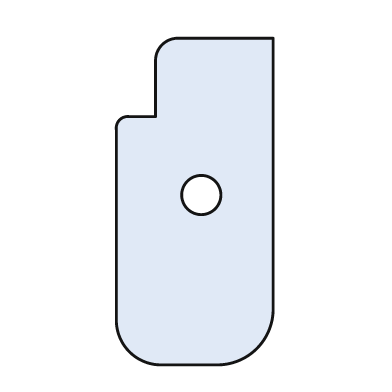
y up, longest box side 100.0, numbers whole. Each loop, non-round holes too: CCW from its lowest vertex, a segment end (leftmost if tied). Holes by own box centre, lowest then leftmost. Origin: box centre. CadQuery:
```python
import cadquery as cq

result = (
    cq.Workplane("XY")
    .moveTo(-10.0, -50.0)
    .lineTo(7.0, -50.0)
    .threePointArc((19.0, -45.0), (24.0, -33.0))
    .lineTo(24.0, 50.0)
    .lineTo(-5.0, 50.0)
    .threePointArc((-10.0, 48.0), (-12.0, 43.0))
    .lineTo(-12.0, 26.0)
    .lineTo(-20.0, 26.0)
    .threePointArc((-23.0, 25.0), (-24.0, 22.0))
    .lineTo(-24.0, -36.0)
    .threePointArc((-20.0, -46.0), (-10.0, -50.0))
    .close()
    .moveTo(2.0, 2.0)
    .circle(6.0)
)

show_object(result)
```